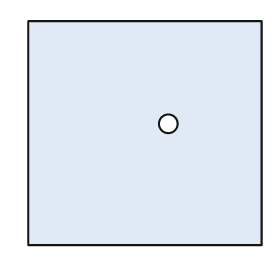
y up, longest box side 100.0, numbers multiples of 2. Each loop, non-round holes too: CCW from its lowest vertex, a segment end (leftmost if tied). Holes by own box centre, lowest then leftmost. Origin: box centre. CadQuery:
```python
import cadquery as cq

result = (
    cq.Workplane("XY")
    .moveTo(-50.0, -48.0)
    .lineTo(50.0, -48.0)
    .lineTo(50.0, 48.0)
    .lineTo(-50.0, 48.0)
    .close()
    .moveTo(10.0, 4.0)
    .circle(4.0)
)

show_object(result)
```